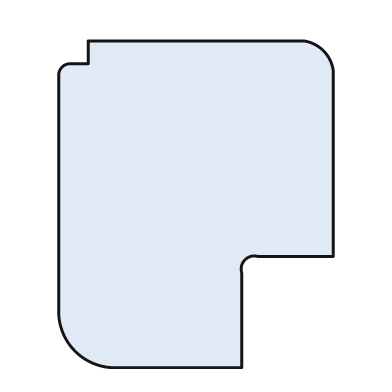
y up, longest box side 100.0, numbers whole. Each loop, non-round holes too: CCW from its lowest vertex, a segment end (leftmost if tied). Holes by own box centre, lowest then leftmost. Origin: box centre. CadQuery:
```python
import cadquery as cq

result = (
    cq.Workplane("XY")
    .moveTo(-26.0, -50.0)
    .lineTo(14.0, -50.0)
    .lineTo(14.0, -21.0)
    .threePointArc((15.0, -17.0), (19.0, -16.0))
    .lineTo(42.0, -16.0)
    .lineTo(42.0, 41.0)
    .threePointArc((39.0, 47.0), (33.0, 50.0))
    .lineTo(-33.0, 50.0)
    .lineTo(-33.0, 43.0)
    .lineTo(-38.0, 43.0)
    .threePointArc((-41.0, 42.0), (-42.0, 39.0))
    .lineTo(-42.0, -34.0)
    .threePointArc((-37.0, -45.0), (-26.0, -50.0))
    .close()
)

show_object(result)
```